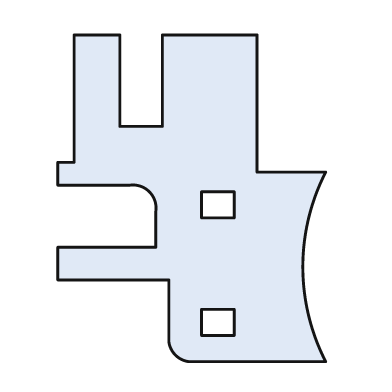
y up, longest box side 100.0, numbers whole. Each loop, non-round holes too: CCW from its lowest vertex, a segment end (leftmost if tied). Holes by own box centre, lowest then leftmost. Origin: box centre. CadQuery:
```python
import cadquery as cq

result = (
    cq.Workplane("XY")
    .moveTo(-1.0, -50.0)
    .lineTo(41.0, -50.0)
    .threePointArc((34.0, -21.0), (41.0, 8.0))
    .lineTo(20.0, 8.0)
    .lineTo(20.0, 50.0)
    .lineTo(-9.0, 50.0)
    .lineTo(-9.0, 22.0)
    .lineTo(-22.0, 22.0)
    .lineTo(-22.0, 50.0)
    .lineTo(-36.0, 50.0)
    .lineTo(-36.0, 11.0)
    .lineTo(-41.0, 11.0)
    .lineTo(-41.0, 4.0)
    .lineTo(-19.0, 4.0)
    .threePointArc((-13.0, 2.0), (-11.0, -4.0))
    .lineTo(-11.0, -15.0)
    .lineTo(-41.0, -15.0)
    .lineTo(-41.0, -25.0)
    .lineTo(-7.0, -25.0)
    .lineTo(-7.0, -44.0)
    .threePointArc((-5.0, -48.0), (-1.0, -50.0))
    .close()
    .moveTo(3.0, -42.0)
    .lineTo(13.0, -42.0)
    .lineTo(13.0, -34.0)
    .lineTo(3.0, -34.0)
    .close()
    .moveTo(3.0, -6.0)
    .lineTo(13.0, -6.0)
    .lineTo(13.0, 2.0)
    .lineTo(3.0, 2.0)
    .close()
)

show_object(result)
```